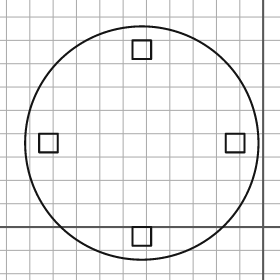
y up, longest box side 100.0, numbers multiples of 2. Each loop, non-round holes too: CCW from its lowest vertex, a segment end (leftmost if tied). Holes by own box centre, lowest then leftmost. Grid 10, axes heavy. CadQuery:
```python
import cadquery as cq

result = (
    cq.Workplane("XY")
    .moveTo(-52.0, 36.0)
    .circle(50.0)
    .moveTo(-56.0, -8.0)
    .lineTo(-48.0, -8.0)
    .lineTo(-48.0, 0.0)
    .lineTo(-56.0, 0.0)
    .close()
    .moveTo(-96.0, 32.0)
    .lineTo(-88.0, 32.0)
    .lineTo(-88.0, 40.0)
    .lineTo(-96.0, 40.0)
    .close()
    .moveTo(-16.0, 32.0)
    .lineTo(-8.0, 32.0)
    .lineTo(-8.0, 40.0)
    .lineTo(-16.0, 40.0)
    .close()
    .moveTo(-56.0, 72.0)
    .lineTo(-48.0, 72.0)
    .lineTo(-48.0, 80.0)
    .lineTo(-56.0, 80.0)
    .close()
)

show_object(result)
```